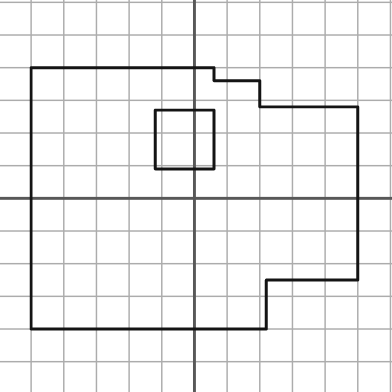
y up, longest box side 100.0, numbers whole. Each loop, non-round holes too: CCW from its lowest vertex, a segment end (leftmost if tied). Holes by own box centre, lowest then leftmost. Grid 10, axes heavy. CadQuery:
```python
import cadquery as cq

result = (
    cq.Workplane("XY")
    .moveTo(-50.0, -40.0)
    .lineTo(22.0, -40.0)
    .lineTo(22.0, -25.0)
    .lineTo(50.0, -25.0)
    .lineTo(50.0, 28.0)
    .lineTo(20.0, 28.0)
    .lineTo(20.0, 36.0)
    .lineTo(6.0, 36.0)
    .lineTo(6.0, 40.0)
    .lineTo(-50.0, 40.0)
    .close()
    .moveTo(-12.0, 9.0)
    .lineTo(6.0, 9.0)
    .lineTo(6.0, 27.0)
    .lineTo(-12.0, 27.0)
    .close()
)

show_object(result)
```